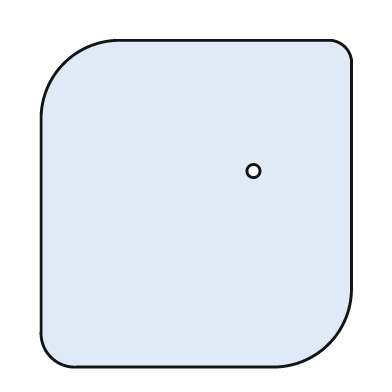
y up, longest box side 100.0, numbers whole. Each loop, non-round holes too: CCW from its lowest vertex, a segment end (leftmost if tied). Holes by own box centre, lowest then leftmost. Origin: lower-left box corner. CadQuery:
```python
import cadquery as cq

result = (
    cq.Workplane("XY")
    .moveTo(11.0, 0.0)
    .lineTo(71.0, 0.0)
    .threePointArc((88.0, 7.0), (95.0, 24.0))
    .lineTo(95.0, 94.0)
    .threePointArc((93.0, 98.0), (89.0, 100.0))
    .lineTo(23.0, 100.0)
    .threePointArc((7.0, 93.0), (0.0, 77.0))
    .lineTo(0.0, 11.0)
    .threePointArc((3.0, 3.0), (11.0, 0.0))
    .close()
    .moveTo(65.0, 60.0)
    .circle(2.0)
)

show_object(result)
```